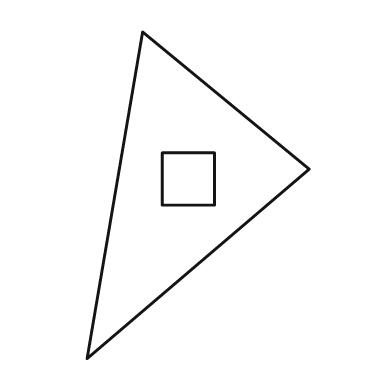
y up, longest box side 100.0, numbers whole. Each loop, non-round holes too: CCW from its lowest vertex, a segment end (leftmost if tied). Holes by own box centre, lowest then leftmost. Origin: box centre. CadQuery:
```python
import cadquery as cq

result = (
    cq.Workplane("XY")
    .moveTo(-34.0, -50.0)
    .lineTo(34.0, 8.0)
    .lineTo(-17.0, 50.0)
    .close()
    .moveTo(-11.0, -3.0)
    .lineTo(5.0, -3.0)
    .lineTo(5.0, 13.0)
    .lineTo(-11.0, 13.0)
    .close()
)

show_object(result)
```